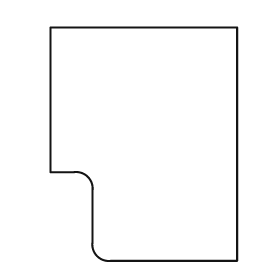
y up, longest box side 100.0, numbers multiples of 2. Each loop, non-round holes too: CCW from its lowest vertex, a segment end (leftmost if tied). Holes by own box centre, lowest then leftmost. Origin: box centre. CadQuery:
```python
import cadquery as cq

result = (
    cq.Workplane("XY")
    .moveTo(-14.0, -50.0)
    .lineTo(40.0, -50.0)
    .lineTo(40.0, 50.0)
    .lineTo(-40.0, 50.0)
    .lineTo(-40.0, -12.0)
    .lineTo(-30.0, -12.0)
    .threePointArc((-24.0, -14.0), (-22.0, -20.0))
    .lineTo(-22.0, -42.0)
    .threePointArc((-20.0, -48.0), (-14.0, -50.0))
    .close()
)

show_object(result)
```